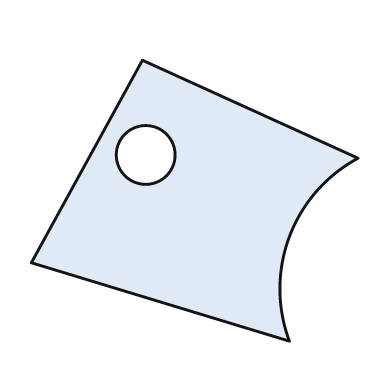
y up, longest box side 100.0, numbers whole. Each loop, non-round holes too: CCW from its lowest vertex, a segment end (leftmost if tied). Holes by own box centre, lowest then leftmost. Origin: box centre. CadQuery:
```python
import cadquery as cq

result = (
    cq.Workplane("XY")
    .moveTo(29.0, -43.0)
    .threePointArc((29.0, -11.0), (50.0, 13.0))
    .lineTo(-16.0, 43.0)
    .lineTo(-50.0, -19.0)
    .close()
    .moveTo(-15.0, 14.0)
    .circle(9.0)
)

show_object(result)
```